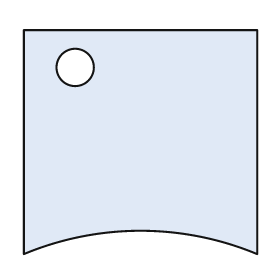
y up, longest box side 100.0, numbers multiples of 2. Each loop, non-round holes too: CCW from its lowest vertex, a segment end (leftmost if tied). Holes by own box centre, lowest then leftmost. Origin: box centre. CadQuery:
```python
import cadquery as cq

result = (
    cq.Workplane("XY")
    .moveTo(-50.0, -48.0)
    .threePointArc((0.0, -38.0), (50.0, -48.0))
    .lineTo(50.0, 48.0)
    .lineTo(-50.0, 48.0)
    .close()
    .moveTo(-28.0, 32.0)
    .circle(8.0)
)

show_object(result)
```